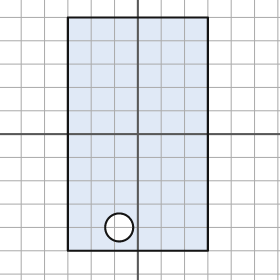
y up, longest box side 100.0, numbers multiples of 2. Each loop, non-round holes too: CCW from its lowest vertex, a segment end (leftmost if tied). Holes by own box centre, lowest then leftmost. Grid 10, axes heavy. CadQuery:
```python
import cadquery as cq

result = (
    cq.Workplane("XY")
    .moveTo(-30.0, -50.0)
    .lineTo(30.0, -50.0)
    .lineTo(30.0, 50.0)
    .lineTo(-30.0, 50.0)
    .close()
    .moveTo(-8.0, -40.0)
    .circle(6.0)
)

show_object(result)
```